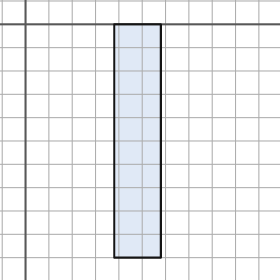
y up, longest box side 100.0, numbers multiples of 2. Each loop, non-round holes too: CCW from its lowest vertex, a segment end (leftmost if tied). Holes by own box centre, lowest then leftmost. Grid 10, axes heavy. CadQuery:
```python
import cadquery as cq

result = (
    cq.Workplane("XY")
    .moveTo(38.0, -100.0)
    .lineTo(58.0, -100.0)
    .lineTo(58.0, 0.0)
    .lineTo(38.0, 0.0)
    .close()
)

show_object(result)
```